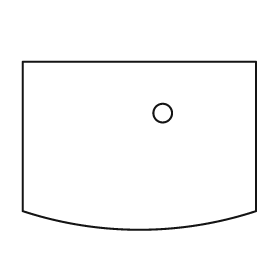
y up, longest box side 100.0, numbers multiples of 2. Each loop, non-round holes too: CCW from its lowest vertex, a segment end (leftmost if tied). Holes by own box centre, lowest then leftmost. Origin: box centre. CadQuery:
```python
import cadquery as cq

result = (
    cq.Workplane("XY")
    .moveTo(-50.0, -28.0)
    .threePointArc((0.0, -36.0), (50.0, -28.0))
    .lineTo(50.0, 36.0)
    .lineTo(-50.0, 36.0)
    .close()
    .moveTo(10.0, 14.0)
    .circle(4.0)
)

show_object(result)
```